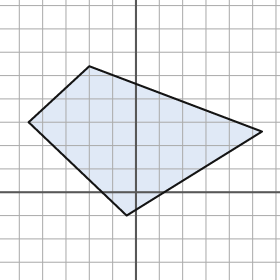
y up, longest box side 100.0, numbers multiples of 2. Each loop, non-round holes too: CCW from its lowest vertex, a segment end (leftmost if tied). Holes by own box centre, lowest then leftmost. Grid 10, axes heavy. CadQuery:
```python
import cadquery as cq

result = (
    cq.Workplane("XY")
    .moveTo(-4.0, -10.0)
    .lineTo(54.0, 26.0)
    .lineTo(-20.0, 54.0)
    .lineTo(-46.0, 30.0)
    .close()
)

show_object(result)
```